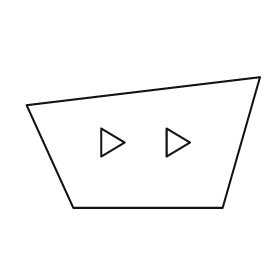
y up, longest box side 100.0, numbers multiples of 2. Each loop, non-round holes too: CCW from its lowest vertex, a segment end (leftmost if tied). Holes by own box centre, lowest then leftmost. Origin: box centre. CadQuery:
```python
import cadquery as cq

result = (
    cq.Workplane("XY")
    .moveTo(-30.0, -28.0)
    .lineTo(34.0, -28.0)
    .lineTo(50.0, 28.0)
    .lineTo(-50.0, 16.0)
    .close()
    .moveTo(-18.0, -6.0)
    .lineTo(-8.0, 0.0)
    .lineTo(-18.0, 6.0)
    .close()
    .moveTo(10.0, -6.0)
    .lineTo(20.0, 0.0)
    .lineTo(10.0, 6.0)
    .close()
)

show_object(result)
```